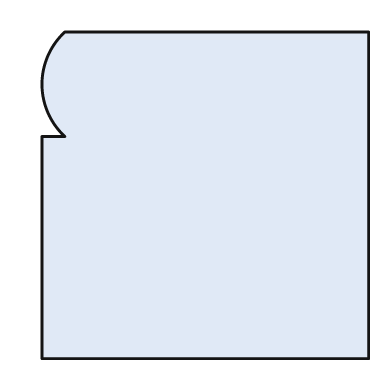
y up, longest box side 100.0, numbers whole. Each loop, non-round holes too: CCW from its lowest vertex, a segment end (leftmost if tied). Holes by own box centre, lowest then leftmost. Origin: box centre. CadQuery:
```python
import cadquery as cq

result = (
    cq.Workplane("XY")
    .moveTo(-50.0, -50.0)
    .lineTo(50.0, -50.0)
    .lineTo(50.0, 50.0)
    .lineTo(-43.0, 50.0)
    .threePointArc((-50.0, 34.0), (-43.0, 18.0))
    .lineTo(-50.0, 18.0)
    .close()
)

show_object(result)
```